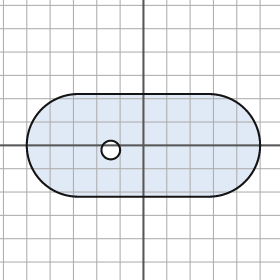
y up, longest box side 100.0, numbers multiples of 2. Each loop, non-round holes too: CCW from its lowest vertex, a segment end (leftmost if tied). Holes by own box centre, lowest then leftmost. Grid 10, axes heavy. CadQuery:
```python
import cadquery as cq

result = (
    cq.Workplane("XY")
    .moveTo(-28.0, -22.0)
    .lineTo(28.0, -22.0)
    .threePointArc((50.0, 0.0), (28.0, 22.0))
    .lineTo(-28.0, 22.0)
    .threePointArc((-50.0, 0.0), (-28.0, -22.0))
    .close()
    .moveTo(-14.0, -2.0)
    .circle(4.0)
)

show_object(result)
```